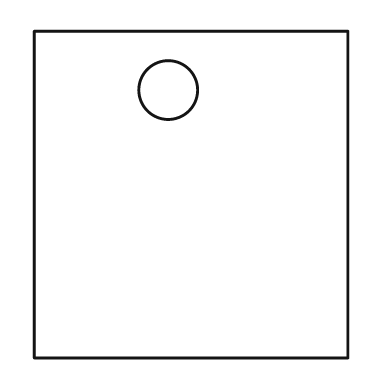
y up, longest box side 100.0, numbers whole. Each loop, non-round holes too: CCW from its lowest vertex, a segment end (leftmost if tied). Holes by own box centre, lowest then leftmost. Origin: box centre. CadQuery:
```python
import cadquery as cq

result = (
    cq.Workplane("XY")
    .moveTo(-48.0, -50.0)
    .lineTo(48.0, -50.0)
    .lineTo(48.0, 50.0)
    .lineTo(-48.0, 50.0)
    .close()
    .moveTo(-7.0, 32.0)
    .circle(9.0)
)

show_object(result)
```